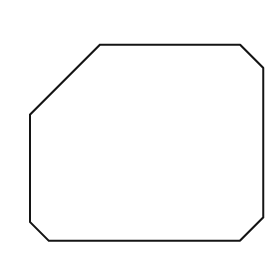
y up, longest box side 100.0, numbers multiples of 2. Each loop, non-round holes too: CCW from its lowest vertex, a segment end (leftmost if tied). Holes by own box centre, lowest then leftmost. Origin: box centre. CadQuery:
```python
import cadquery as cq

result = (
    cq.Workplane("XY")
    .moveTo(-42.0, -42.0)
    .lineTo(40.0, -42.0)
    .lineTo(50.0, -32.0)
    .lineTo(50.0, 32.0)
    .lineTo(40.0, 42.0)
    .lineTo(-20.0, 42.0)
    .lineTo(-50.0, 12.0)
    .lineTo(-50.0, -34.0)
    .close()
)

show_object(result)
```